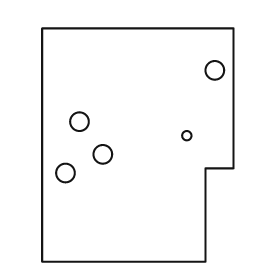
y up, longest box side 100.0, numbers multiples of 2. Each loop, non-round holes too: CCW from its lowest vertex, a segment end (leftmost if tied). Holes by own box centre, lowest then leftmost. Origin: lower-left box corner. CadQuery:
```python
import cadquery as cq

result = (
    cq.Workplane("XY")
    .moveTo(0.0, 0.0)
    .lineTo(70.0, 0.0)
    .lineTo(70.0, 40.0)
    .lineTo(82.0, 40.0)
    .lineTo(82.0, 100.0)
    .lineTo(0.0, 100.0)
    .close()
    .moveTo(10.0, 38.0)
    .circle(4.0)
    .moveTo(26.0, 46.0)
    .circle(4.0)
    .moveTo(62.0, 54.0)
    .circle(2.0)
    .moveTo(16.0, 60.0)
    .circle(4.0)
    .moveTo(74.0, 82.0)
    .circle(4.0)
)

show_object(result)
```